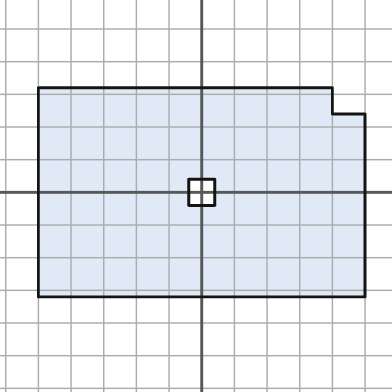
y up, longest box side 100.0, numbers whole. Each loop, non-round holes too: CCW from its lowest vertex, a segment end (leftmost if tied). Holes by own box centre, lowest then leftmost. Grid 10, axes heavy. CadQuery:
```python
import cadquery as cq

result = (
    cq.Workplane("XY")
    .moveTo(-50.0, -32.0)
    .lineTo(50.0, -32.0)
    .lineTo(50.0, 24.0)
    .lineTo(40.0, 24.0)
    .lineTo(40.0, 32.0)
    .lineTo(-50.0, 32.0)
    .close()
    .moveTo(-4.0, -4.0)
    .lineTo(4.0, -4.0)
    .lineTo(4.0, 4.0)
    .lineTo(-4.0, 4.0)
    .close()
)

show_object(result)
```